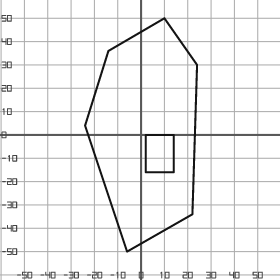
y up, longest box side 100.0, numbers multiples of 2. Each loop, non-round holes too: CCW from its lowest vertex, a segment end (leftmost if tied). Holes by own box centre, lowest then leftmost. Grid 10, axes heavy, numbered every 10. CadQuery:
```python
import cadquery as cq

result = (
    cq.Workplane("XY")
    .moveTo(-6.0, -50.0)
    .lineTo(22.0, -34.0)
    .lineTo(24.0, 30.0)
    .lineTo(10.0, 50.0)
    .lineTo(-14.0, 36.0)
    .lineTo(-24.0, 4.0)
    .close()
    .moveTo(2.0, -16.0)
    .lineTo(14.0, -16.0)
    .lineTo(14.0, 0.0)
    .lineTo(2.0, 0.0)
    .close()
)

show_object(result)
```